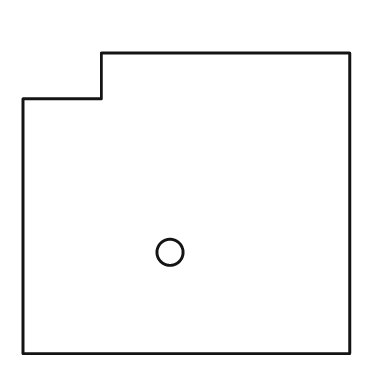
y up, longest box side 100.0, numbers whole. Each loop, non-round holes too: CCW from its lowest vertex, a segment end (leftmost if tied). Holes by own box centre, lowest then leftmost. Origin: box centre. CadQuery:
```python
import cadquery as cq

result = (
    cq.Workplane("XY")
    .moveTo(-50.0, -46.0)
    .lineTo(50.0, -46.0)
    .lineTo(50.0, 46.0)
    .lineTo(-26.0, 46.0)
    .lineTo(-26.0, 32.0)
    .lineTo(-50.0, 32.0)
    .close()
    .moveTo(-5.0, -15.0)
    .circle(4.0)
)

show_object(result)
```